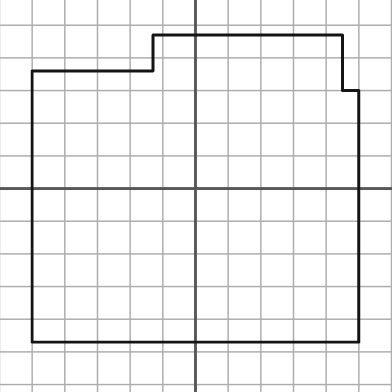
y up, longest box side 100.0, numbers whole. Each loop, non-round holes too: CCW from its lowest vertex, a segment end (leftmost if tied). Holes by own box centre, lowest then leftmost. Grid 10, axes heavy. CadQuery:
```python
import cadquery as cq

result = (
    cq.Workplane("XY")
    .moveTo(-50.0, -47.0)
    .lineTo(50.0, -47.0)
    .lineTo(50.0, 30.0)
    .lineTo(45.0, 30.0)
    .lineTo(45.0, 47.0)
    .lineTo(-13.0, 47.0)
    .lineTo(-13.0, 36.0)
    .lineTo(-50.0, 36.0)
    .close()
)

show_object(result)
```